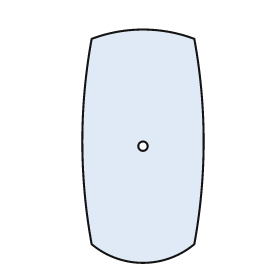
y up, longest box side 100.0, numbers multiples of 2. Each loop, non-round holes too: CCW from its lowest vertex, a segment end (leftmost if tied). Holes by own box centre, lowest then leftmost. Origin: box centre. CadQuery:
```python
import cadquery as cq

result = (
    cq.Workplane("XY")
    .moveTo(-22.0, -42.0)
    .threePointArc((0.0, -50.0), (22.0, -42.0))
    .threePointArc((26.0, 2.0), (22.0, 46.0))
    .threePointArc((0.0, 50.0), (-22.0, 46.0))
    .threePointArc((-26.0, 2.0), (-22.0, -42.0))
    .close()
    .moveTo(0.0, 0.0)
    .circle(2.0)
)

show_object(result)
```